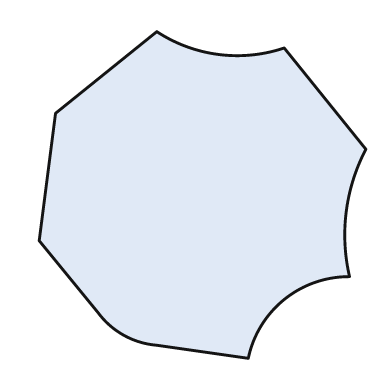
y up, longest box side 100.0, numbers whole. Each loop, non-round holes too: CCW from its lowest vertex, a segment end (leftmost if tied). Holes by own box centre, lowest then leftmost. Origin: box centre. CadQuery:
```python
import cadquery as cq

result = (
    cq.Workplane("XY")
    .moveTo(14.0, -50.0)
    .threePointArc((25.0, -32.0), (45.0, -25.0))
    .threePointArc((44.0, -5.0), (50.0, 14.0))
    .lineTo(25.0, 45.0)
    .threePointArc((5.0, 43.0), (-14.0, 50.0))
    .lineTo(-45.0, 25.0)
    .lineTo(-50.0, -14.0)
    .lineTo(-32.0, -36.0)
    .threePointArc((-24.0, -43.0), (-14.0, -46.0))
    .close()
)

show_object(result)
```